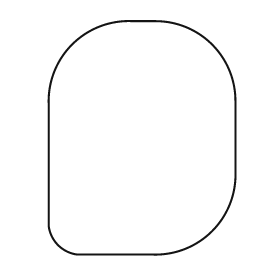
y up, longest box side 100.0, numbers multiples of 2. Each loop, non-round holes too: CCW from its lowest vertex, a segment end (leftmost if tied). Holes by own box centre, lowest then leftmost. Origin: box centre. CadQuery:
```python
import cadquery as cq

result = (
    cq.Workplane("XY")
    .moveTo(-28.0, -50.0)
    .lineTo(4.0, -50.0)
    .threePointArc((30.0, -40.0), (40.0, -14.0))
    .lineTo(40.0, 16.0)
    .threePointArc((30.0, 40.0), (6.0, 50.0))
    .lineTo(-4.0, 50.0)
    .threePointArc((-30.0, 40.0), (-40.0, 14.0))
    .lineTo(-40.0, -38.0)
    .threePointArc((-36.0, -46.0), (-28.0, -50.0))
    .close()
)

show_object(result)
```